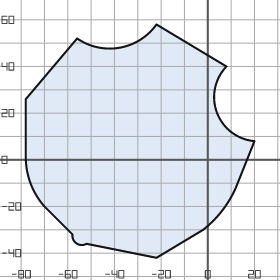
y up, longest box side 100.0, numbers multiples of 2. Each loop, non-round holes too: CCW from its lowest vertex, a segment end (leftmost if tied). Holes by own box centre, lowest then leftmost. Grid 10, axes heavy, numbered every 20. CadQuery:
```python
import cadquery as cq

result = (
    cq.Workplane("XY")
    .moveTo(-22.0, -42.0)
    .lineTo(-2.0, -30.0)
    .threePointArc((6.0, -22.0), (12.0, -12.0))
    .lineTo(20.0, 8.0)
    .threePointArc((4.0, 20.0), (8.0, 40.0))
    .lineTo(-22.0, 58.0)
    .threePointArc((-38.0, 48.0), (-56.0, 52.0))
    .lineTo(-78.0, 26.0)
    .lineTo(-78.0, 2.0)
    .threePointArc((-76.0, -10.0), (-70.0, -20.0))
    .lineTo(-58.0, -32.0)
    .threePointArc((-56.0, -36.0), (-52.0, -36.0))
    .close()
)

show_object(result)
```